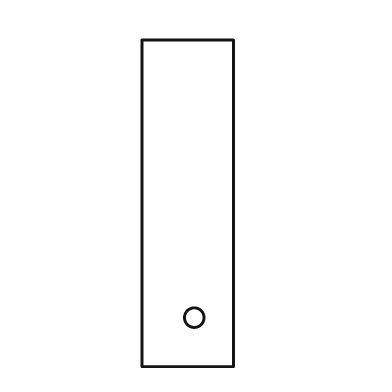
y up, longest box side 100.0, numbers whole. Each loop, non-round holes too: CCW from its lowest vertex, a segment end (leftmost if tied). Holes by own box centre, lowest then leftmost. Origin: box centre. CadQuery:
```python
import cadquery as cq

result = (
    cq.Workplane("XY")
    .moveTo(-14.0, -50.0)
    .lineTo(14.0, -50.0)
    .lineTo(14.0, 50.0)
    .lineTo(-14.0, 50.0)
    .close()
    .moveTo(2.0, -35.0)
    .circle(3.0)
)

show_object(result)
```